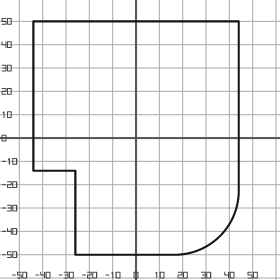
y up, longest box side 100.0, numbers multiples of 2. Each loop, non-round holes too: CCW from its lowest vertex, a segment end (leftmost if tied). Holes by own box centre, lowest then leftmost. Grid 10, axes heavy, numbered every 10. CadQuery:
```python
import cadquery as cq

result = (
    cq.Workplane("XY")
    .moveTo(-26.0, -50.0)
    .lineTo(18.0, -50.0)
    .threePointArc((36.0, -42.0), (44.0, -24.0))
    .lineTo(44.0, 50.0)
    .lineTo(-44.0, 50.0)
    .lineTo(-44.0, -14.0)
    .lineTo(-26.0, -14.0)
    .close()
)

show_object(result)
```